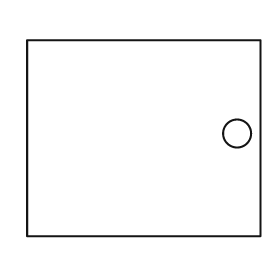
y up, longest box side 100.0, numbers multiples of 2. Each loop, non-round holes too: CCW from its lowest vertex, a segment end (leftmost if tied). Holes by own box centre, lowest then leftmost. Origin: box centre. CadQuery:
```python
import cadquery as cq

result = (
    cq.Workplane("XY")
    .moveTo(-50.0, -42.0)
    .lineTo(50.0, -42.0)
    .lineTo(50.0, 42.0)
    .lineTo(-50.0, 42.0)
    .close()
    .moveTo(40.0, 2.0)
    .circle(6.0)
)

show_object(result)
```